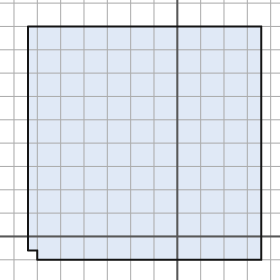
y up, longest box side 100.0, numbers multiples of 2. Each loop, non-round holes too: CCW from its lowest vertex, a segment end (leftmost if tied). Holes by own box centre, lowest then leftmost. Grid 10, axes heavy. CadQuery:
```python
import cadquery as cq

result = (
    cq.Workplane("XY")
    .moveTo(-60.0, -10.0)
    .lineTo(36.0, -10.0)
    .lineTo(36.0, 90.0)
    .lineTo(-64.0, 90.0)
    .lineTo(-64.0, -6.0)
    .lineTo(-60.0, -6.0)
    .close()
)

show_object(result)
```